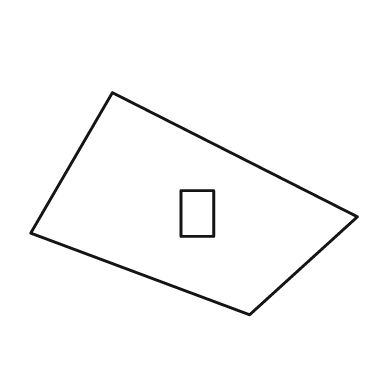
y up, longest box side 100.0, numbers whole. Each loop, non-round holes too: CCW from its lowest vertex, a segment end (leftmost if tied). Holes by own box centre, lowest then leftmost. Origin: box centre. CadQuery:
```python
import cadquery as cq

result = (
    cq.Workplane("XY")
    .moveTo(17.0, -34.0)
    .lineTo(50.0, -4.0)
    .lineTo(-25.0, 34.0)
    .lineTo(-50.0, -9.0)
    .close()
    .moveTo(-4.0, -10.0)
    .lineTo(6.0, -10.0)
    .lineTo(6.0, 4.0)
    .lineTo(-4.0, 4.0)
    .close()
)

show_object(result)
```